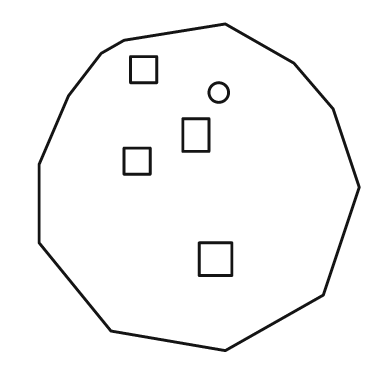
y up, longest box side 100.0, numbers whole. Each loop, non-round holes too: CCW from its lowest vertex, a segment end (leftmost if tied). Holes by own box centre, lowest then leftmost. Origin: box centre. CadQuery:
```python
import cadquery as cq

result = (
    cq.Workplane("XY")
    .moveTo(8.0, -50.0)
    .lineTo(38.0, -33.0)
    .lineTo(49.0, 0.0)
    .lineTo(41.0, 24.0)
    .lineTo(29.0, 38.0)
    .lineTo(8.0, 50.0)
    .lineTo(-23.0, 45.0)
    .lineTo(-30.0, 41.0)
    .lineTo(-40.0, 28.0)
    .lineTo(-49.0, 7.0)
    .lineTo(-49.0, -17.0)
    .lineTo(-27.0, -44.0)
    .close()
    .moveTo(0.0, -27.0)
    .lineTo(10.0, -27.0)
    .lineTo(10.0, -17.0)
    .lineTo(0.0, -17.0)
    .close()
    .moveTo(-23.0, 4.0)
    .lineTo(-15.0, 4.0)
    .lineTo(-15.0, 12.0)
    .lineTo(-23.0, 12.0)
    .close()
    .moveTo(-5.0, 11.0)
    .lineTo(3.0, 11.0)
    .lineTo(3.0, 21.0)
    .lineTo(-5.0, 21.0)
    .close()
    .moveTo(6.0, 29.0)
    .circle(3.0)
    .moveTo(-21.0, 32.0)
    .lineTo(-13.0, 32.0)
    .lineTo(-13.0, 40.0)
    .lineTo(-21.0, 40.0)
    .close()
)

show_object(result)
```